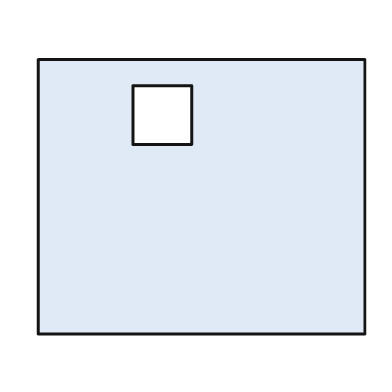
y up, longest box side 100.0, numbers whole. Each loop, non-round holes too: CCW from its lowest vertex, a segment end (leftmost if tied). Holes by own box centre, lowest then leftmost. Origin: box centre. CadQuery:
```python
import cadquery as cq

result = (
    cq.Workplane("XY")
    .moveTo(-50.0, -42.0)
    .lineTo(50.0, -42.0)
    .lineTo(50.0, 42.0)
    .lineTo(-50.0, 42.0)
    .close()
    .moveTo(-21.0, 16.0)
    .lineTo(-3.0, 16.0)
    .lineTo(-3.0, 34.0)
    .lineTo(-21.0, 34.0)
    .close()
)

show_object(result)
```